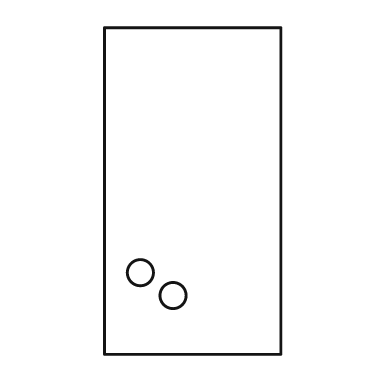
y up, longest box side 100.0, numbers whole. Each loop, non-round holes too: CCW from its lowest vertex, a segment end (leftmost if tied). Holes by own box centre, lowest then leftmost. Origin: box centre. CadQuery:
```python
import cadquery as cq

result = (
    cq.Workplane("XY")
    .moveTo(-27.0, -50.0)
    .lineTo(27.0, -50.0)
    .lineTo(27.0, 50.0)
    .lineTo(-27.0, 50.0)
    .close()
    .moveTo(-6.0, -32.0)
    .circle(4.0)
    .moveTo(-16.0, -25.0)
    .circle(4.0)
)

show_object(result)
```